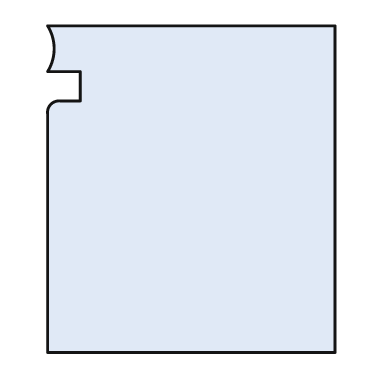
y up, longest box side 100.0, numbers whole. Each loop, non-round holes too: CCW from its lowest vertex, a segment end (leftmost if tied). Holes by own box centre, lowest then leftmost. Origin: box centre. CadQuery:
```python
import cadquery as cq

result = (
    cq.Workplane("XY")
    .moveTo(-44.0, -50.0)
    .lineTo(44.0, -50.0)
    .lineTo(44.0, 50.0)
    .lineTo(-44.0, 50.0)
    .threePointArc((-42.0, 43.0), (-44.0, 36.0))
    .lineTo(-34.0, 36.0)
    .lineTo(-34.0, 27.0)
    .lineTo(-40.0, 27.0)
    .threePointArc((-43.0, 26.0), (-44.0, 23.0))
    .close()
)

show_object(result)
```